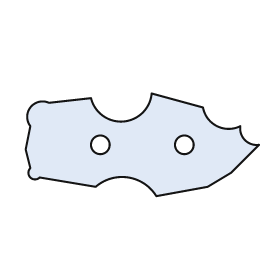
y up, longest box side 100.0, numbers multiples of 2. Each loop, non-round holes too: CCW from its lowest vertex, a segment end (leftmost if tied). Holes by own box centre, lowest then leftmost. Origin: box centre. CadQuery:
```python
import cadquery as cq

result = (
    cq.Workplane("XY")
    .moveTo(6.0, -22.0)
    .lineTo(28.0, -18.0)
    .lineTo(38.0, -12.0)
    .lineTo(50.0, 0.0)
    .threePointArc((44.0, 2.0), (42.0, 8.0))
    .threePointArc((32.0, 8.0), (26.0, 16.0))
    .lineTo(4.0, 22.0)
    .threePointArc((-8.0, 10.0), (-22.0, 20.0))
    .lineTo(-40.0, 18.0)
    .threePointArc((-48.0, 16.0), (-48.0, 8.0))
    .lineTo(-50.0, -2.0)
    .lineTo(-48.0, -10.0)
    .threePointArc((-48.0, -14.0), (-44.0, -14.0))
    .lineTo(-20.0, -18.0)
    .threePointArc((-6.0, -14.0), (6.0, -22.0))
    .close()
    .moveTo(-18.0, 0.0)
    .circle(4.0)
    .moveTo(18.0, 0.0)
    .circle(4.0)
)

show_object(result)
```